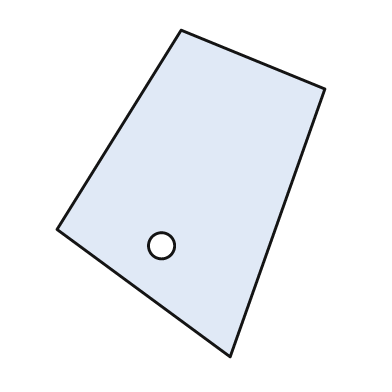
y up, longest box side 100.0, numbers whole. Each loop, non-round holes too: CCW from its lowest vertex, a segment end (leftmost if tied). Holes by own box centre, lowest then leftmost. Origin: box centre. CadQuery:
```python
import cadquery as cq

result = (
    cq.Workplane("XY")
    .moveTo(12.0, -50.0)
    .lineTo(41.0, 32.0)
    .lineTo(-3.0, 50.0)
    .lineTo(-41.0, -11.0)
    .close()
    .moveTo(-9.0, -16.0)
    .circle(4.0)
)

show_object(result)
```